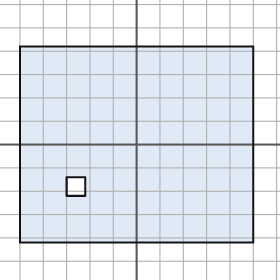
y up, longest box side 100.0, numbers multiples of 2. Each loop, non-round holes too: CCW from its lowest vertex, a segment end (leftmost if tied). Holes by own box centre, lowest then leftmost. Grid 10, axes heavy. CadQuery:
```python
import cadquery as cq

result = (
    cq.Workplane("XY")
    .moveTo(-50.0, -42.0)
    .lineTo(50.0, -42.0)
    .lineTo(50.0, 42.0)
    .lineTo(-50.0, 42.0)
    .close()
    .moveTo(-30.0, -22.0)
    .lineTo(-22.0, -22.0)
    .lineTo(-22.0, -14.0)
    .lineTo(-30.0, -14.0)
    .close()
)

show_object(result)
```